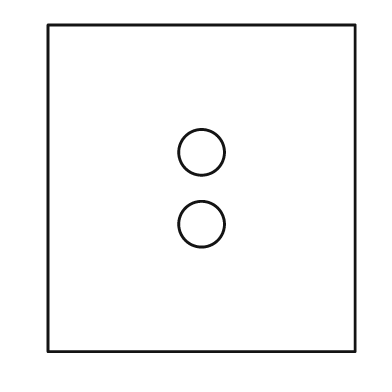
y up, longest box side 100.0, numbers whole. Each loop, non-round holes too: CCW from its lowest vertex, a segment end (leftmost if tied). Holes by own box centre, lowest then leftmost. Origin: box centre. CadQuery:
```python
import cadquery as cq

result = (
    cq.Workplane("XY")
    .moveTo(-47.0, -50.0)
    .lineTo(47.0, -50.0)
    .lineTo(47.0, 50.0)
    .lineTo(-47.0, 50.0)
    .close()
    .moveTo(0.0, -11.0)
    .circle(7.0)
    .moveTo(0.0, 11.0)
    .circle(7.0)
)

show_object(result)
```